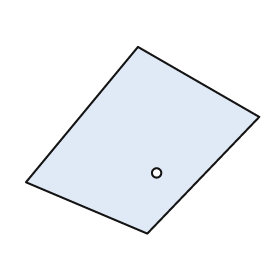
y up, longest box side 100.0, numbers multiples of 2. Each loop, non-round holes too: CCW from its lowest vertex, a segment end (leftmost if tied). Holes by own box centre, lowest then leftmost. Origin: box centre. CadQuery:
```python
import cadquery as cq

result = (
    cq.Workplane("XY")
    .moveTo(2.0, -40.0)
    .lineTo(50.0, 10.0)
    .lineTo(-2.0, 40.0)
    .lineTo(-50.0, -18.0)
    .close()
    .moveTo(6.0, -14.0)
    .circle(2.0)
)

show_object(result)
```